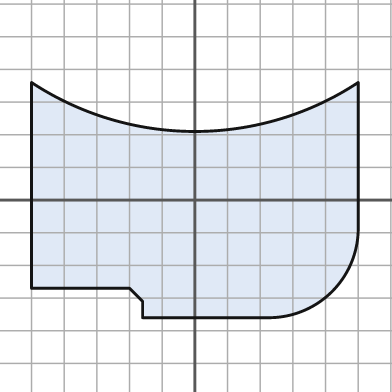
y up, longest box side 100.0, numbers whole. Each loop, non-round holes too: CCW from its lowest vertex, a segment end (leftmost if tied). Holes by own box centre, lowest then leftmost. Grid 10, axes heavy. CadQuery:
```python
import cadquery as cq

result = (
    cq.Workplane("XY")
    .moveTo(-16.0, -36.0)
    .lineTo(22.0, -36.0)
    .threePointArc((42.0, -28.0), (50.0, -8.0))
    .lineTo(50.0, 36.0)
    .threePointArc((0.0, 21.0), (-50.0, 36.0))
    .lineTo(-50.0, -27.0)
    .lineTo(-20.0, -27.0)
    .lineTo(-16.0, -31.0)
    .close()
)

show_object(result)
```